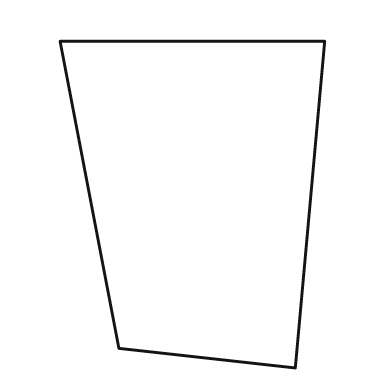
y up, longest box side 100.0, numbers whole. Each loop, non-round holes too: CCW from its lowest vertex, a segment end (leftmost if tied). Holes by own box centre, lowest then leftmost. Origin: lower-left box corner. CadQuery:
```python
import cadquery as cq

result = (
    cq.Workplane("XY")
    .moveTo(72.0, 0.0)
    .lineTo(81.0, 100.0)
    .lineTo(0.0, 100.0)
    .lineTo(18.0, 6.0)
    .close()
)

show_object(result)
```